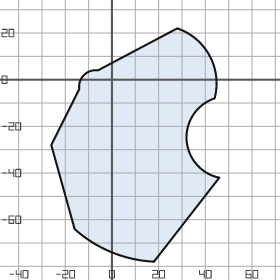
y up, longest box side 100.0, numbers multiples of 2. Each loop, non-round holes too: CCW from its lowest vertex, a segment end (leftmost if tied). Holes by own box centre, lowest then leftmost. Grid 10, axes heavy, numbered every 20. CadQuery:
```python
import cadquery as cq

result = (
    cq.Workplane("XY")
    .moveTo(18.0, -78.0)
    .lineTo(46.0, -42.0)
    .threePointArc((32.0, -26.0), (44.0, -8.0))
    .threePointArc((42.0, 10.0), (28.0, 22.0))
    .lineTo(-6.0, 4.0)
    .threePointArc((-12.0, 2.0), (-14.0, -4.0))
    .lineTo(-26.0, -28.0)
    .lineTo(-16.0, -64.0)
    .threePointArc((0.0, -74.0), (18.0, -78.0))
    .close()
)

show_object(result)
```